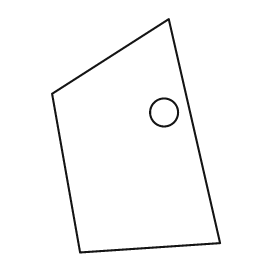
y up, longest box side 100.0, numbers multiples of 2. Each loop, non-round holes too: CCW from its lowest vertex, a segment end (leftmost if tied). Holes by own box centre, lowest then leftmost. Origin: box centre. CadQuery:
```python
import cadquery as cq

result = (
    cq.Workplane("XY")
    .moveTo(-24.0, -50.0)
    .lineTo(36.0, -46.0)
    .lineTo(14.0, 50.0)
    .lineTo(-36.0, 18.0)
    .close()
    .moveTo(12.0, 10.0)
    .circle(6.0)
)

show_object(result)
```